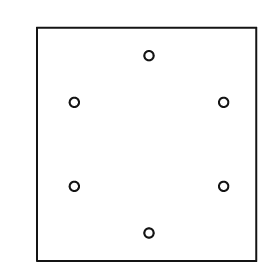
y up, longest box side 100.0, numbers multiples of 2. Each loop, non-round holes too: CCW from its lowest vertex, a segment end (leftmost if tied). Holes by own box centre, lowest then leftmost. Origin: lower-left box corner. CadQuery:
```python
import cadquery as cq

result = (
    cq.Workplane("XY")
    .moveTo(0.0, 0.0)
    .lineTo(94.0, 0.0)
    .lineTo(94.0, 100.0)
    .lineTo(0.0, 100.0)
    .close()
    .moveTo(48.0, 12.0)
    .circle(2.0)
    .moveTo(16.0, 32.0)
    .circle(2.0)
    .moveTo(80.0, 32.0)
    .circle(2.0)
    .moveTo(16.0, 68.0)
    .circle(2.0)
    .moveTo(80.0, 68.0)
    .circle(2.0)
    .moveTo(48.0, 88.0)
    .circle(2.0)
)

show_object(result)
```